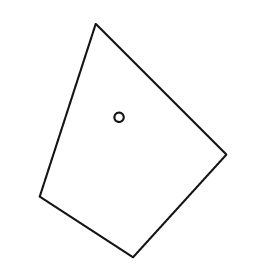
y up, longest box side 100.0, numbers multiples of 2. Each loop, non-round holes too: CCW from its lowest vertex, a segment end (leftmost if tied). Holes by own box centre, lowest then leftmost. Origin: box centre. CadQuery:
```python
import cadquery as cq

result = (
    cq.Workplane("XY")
    .moveTo(0.0, -50.0)
    .lineTo(40.0, -6.0)
    .lineTo(-16.0, 50.0)
    .lineTo(-40.0, -24.0)
    .close()
    .moveTo(-6.0, 10.0)
    .circle(2.0)
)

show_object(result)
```